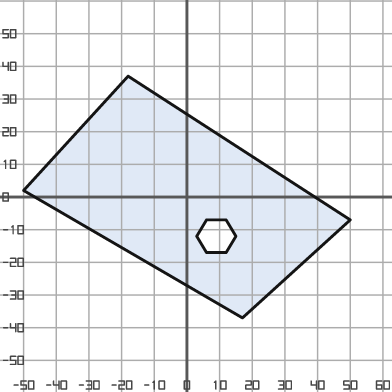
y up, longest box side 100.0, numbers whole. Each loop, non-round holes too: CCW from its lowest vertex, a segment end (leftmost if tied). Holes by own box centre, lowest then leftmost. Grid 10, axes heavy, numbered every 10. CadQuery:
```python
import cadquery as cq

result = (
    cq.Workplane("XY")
    .moveTo(17.0, -37.0)
    .lineTo(50.0, -7.0)
    .lineTo(-18.0, 37.0)
    .lineTo(-50.0, 2.0)
    .close()
    .moveTo(6.0, -17.0)
    .lineTo(12.0, -17.0)
    .lineTo(15.0, -12.0)
    .lineTo(12.0, -7.0)
    .lineTo(6.0, -7.0)
    .lineTo(3.0, -12.0)
    .close()
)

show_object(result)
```